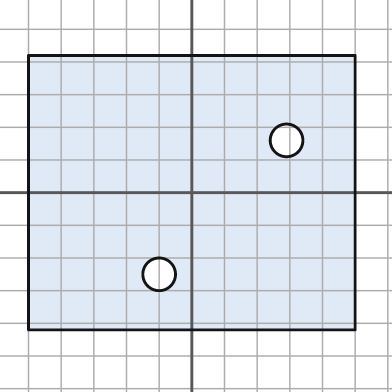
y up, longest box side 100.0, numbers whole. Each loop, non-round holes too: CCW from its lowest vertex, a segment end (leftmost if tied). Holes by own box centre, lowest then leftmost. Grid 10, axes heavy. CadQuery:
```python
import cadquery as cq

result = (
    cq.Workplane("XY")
    .moveTo(-50.0, -42.0)
    .lineTo(50.0, -42.0)
    .lineTo(50.0, 42.0)
    .lineTo(-50.0, 42.0)
    .close()
    .moveTo(-10.0, -25.0)
    .circle(5.0)
    .moveTo(29.0, 16.0)
    .circle(5.0)
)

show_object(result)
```